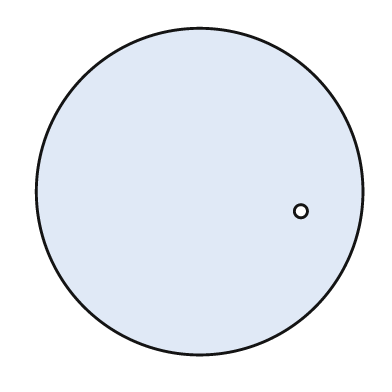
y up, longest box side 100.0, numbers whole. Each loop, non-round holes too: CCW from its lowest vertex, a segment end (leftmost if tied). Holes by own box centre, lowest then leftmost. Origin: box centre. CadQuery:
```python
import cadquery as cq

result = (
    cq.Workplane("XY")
    .moveTo(0.0, 0.0)
    .circle(50.0)
    .moveTo(31.0, -6.0)
    .circle(2.0)
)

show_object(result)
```